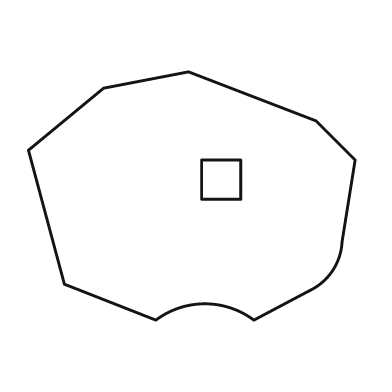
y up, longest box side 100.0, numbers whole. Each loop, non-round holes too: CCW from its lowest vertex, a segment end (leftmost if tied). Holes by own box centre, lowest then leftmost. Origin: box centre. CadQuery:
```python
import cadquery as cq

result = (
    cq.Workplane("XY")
    .moveTo(-11.0, -38.0)
    .threePointArc((4.0, -33.0), (19.0, -38.0))
    .lineTo(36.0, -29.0)
    .threePointArc((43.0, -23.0), (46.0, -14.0))
    .lineTo(50.0, 11.0)
    .lineTo(38.0, 23.0)
    .lineTo(-1.0, 38.0)
    .lineTo(-27.0, 33.0)
    .lineTo(-50.0, 14.0)
    .lineTo(-39.0, -27.0)
    .close()
    .moveTo(3.0, -1.0)
    .lineTo(15.0, -1.0)
    .lineTo(15.0, 11.0)
    .lineTo(3.0, 11.0)
    .close()
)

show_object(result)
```